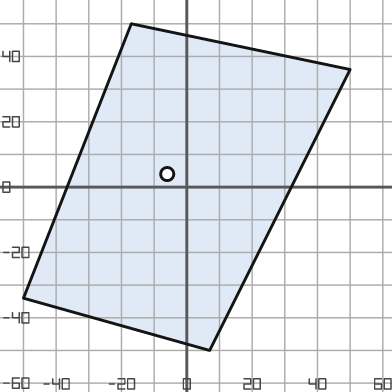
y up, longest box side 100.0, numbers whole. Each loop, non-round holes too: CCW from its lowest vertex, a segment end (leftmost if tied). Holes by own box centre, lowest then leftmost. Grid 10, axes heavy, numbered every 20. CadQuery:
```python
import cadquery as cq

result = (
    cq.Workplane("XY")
    .moveTo(7.0, -50.0)
    .lineTo(50.0, 36.0)
    .lineTo(-17.0, 50.0)
    .lineTo(-50.0, -34.0)
    .close()
    .moveTo(-6.0, 4.0)
    .circle(2.0)
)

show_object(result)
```